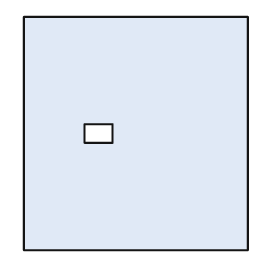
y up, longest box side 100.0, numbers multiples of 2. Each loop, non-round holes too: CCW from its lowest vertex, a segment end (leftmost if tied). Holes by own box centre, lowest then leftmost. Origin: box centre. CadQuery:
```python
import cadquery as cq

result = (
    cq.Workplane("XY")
    .moveTo(-48.0, -50.0)
    .lineTo(48.0, -50.0)
    .lineTo(48.0, 50.0)
    .lineTo(-48.0, 50.0)
    .close()
    .moveTo(-22.0, -4.0)
    .lineTo(-10.0, -4.0)
    .lineTo(-10.0, 4.0)
    .lineTo(-22.0, 4.0)
    .close()
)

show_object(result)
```